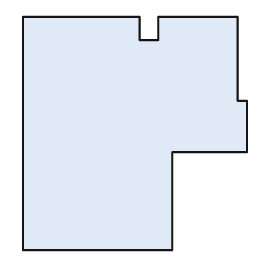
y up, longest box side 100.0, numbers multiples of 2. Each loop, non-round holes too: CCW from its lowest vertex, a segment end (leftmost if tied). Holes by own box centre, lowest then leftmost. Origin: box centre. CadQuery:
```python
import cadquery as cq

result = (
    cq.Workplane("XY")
    .moveTo(-48.0, -50.0)
    .lineTo(16.0, -50.0)
    .lineTo(16.0, -8.0)
    .lineTo(48.0, -8.0)
    .lineTo(48.0, 14.0)
    .lineTo(44.0, 14.0)
    .lineTo(44.0, 50.0)
    .lineTo(10.0, 50.0)
    .lineTo(10.0, 40.0)
    .lineTo(2.0, 40.0)
    .lineTo(2.0, 50.0)
    .lineTo(-48.0, 50.0)
    .close()
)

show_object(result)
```